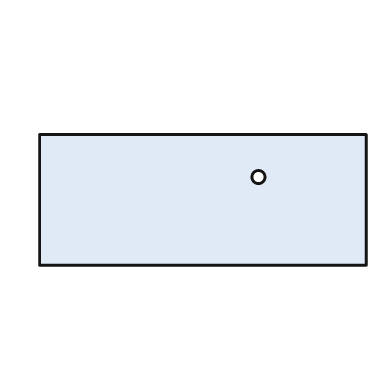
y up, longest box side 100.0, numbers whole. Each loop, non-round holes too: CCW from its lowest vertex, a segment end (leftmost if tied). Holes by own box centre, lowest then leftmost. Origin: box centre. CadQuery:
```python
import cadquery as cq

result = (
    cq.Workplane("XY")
    .moveTo(-50.0, -20.0)
    .lineTo(50.0, -20.0)
    .lineTo(50.0, 20.0)
    .lineTo(-50.0, 20.0)
    .close()
    .moveTo(17.0, 7.0)
    .circle(2.0)
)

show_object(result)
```